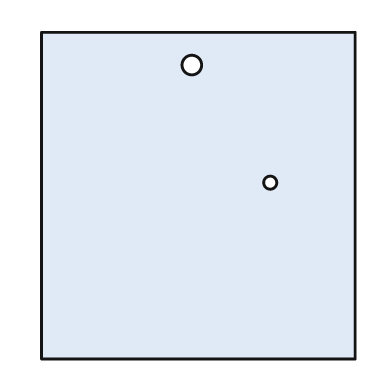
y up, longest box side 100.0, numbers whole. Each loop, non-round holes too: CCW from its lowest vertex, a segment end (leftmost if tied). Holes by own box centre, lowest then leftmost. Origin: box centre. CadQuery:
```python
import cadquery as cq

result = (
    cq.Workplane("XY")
    .moveTo(-48.0, -50.0)
    .lineTo(48.0, -50.0)
    .lineTo(48.0, 50.0)
    .lineTo(-48.0, 50.0)
    .close()
    .moveTo(22.0, 4.0)
    .circle(2.0)
    .moveTo(-2.0, 40.0)
    .circle(3.0)
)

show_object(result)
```